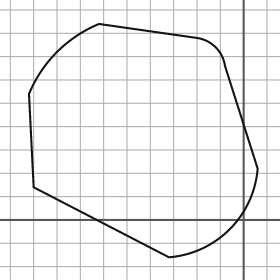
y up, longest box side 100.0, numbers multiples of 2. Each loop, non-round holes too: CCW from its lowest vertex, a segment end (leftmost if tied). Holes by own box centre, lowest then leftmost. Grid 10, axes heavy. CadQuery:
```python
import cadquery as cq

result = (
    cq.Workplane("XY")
    .moveTo(-32.0, -16.0)
    .threePointArc((-6.0, -4.0), (6.0, 22.0))
    .lineTo(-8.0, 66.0)
    .threePointArc((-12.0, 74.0), (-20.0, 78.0))
    .lineTo(-62.0, 84.0)
    .threePointArc((-80.0, 72.0), (-92.0, 54.0))
    .lineTo(-90.0, 14.0)
    .close()
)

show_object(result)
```